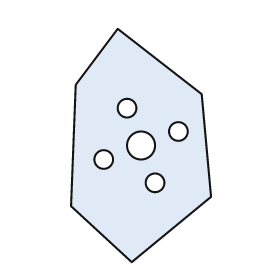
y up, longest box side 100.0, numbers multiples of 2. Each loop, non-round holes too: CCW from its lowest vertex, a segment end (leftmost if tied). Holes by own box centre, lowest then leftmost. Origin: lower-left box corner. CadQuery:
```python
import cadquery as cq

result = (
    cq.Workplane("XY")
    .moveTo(26.0, 0.0)
    .lineTo(60.0, 28.0)
    .lineTo(56.0, 72.0)
    .lineTo(20.0, 100.0)
    .lineTo(2.0, 76.0)
    .lineTo(0.0, 24.0)
    .close()
    .moveTo(36.0, 34.0)
    .circle(4.0)
    .moveTo(14.0, 44.0)
    .circle(4.0)
    .moveTo(30.0, 50.0)
    .circle(6.0)
    .moveTo(46.0, 56.0)
    .circle(4.0)
    .moveTo(24.0, 66.0)
    .circle(4.0)
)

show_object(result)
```